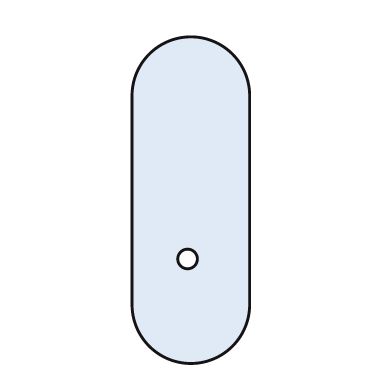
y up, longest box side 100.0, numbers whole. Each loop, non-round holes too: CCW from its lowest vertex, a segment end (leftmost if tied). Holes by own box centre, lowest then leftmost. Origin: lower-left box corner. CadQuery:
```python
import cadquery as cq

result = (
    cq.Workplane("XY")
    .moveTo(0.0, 18.0)
    .threePointArc((18.0, 0.0), (36.0, 18.0))
    .lineTo(36.0, 82.0)
    .threePointArc((18.0, 100.0), (0.0, 82.0))
    .close()
    .moveTo(17.0, 32.0)
    .circle(3.0)
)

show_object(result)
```